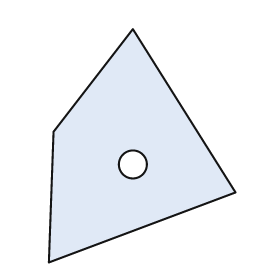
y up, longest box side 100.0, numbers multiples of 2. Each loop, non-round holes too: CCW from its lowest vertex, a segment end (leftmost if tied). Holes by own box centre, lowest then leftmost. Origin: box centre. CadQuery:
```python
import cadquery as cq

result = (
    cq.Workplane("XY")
    .moveTo(-40.0, -50.0)
    .lineTo(40.0, -20.0)
    .lineTo(-4.0, 50.0)
    .lineTo(-38.0, 6.0)
    .close()
    .moveTo(-4.0, -8.0)
    .circle(6.0)
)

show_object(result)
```